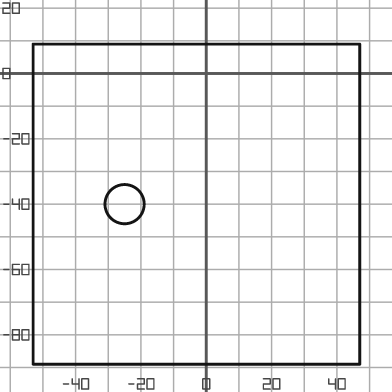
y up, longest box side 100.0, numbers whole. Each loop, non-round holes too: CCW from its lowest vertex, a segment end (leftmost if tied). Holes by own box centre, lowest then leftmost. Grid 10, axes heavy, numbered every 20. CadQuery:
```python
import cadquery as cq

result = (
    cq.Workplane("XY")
    .moveTo(-53.0, -89.0)
    .lineTo(47.0, -89.0)
    .lineTo(47.0, 9.0)
    .lineTo(-53.0, 9.0)
    .close()
    .moveTo(-25.0, -40.0)
    .circle(6.0)
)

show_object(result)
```